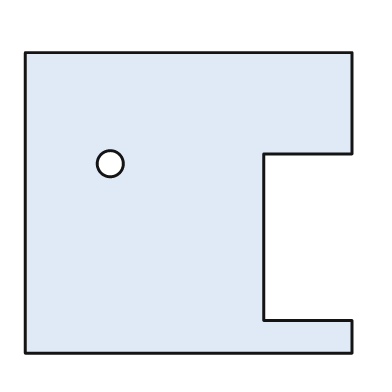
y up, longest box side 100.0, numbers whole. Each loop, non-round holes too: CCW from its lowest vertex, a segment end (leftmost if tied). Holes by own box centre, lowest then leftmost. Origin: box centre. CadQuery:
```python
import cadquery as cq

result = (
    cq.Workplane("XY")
    .moveTo(-50.0, -46.0)
    .lineTo(50.0, -46.0)
    .lineTo(50.0, -36.0)
    .lineTo(23.0, -36.0)
    .lineTo(23.0, 15.0)
    .lineTo(50.0, 15.0)
    .lineTo(50.0, 46.0)
    .lineTo(-50.0, 46.0)
    .close()
    .moveTo(-24.0, 12.0)
    .circle(4.0)
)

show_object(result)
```